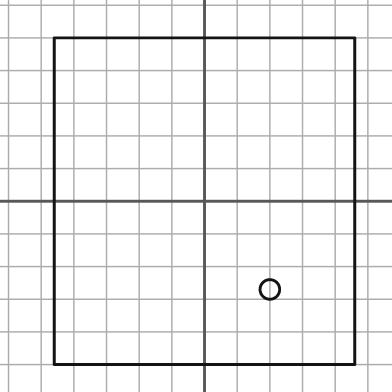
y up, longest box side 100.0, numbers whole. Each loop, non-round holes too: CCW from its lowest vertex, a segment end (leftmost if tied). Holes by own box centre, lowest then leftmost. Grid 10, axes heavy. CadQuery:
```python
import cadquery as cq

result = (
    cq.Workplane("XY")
    .moveTo(-46.0, -50.0)
    .lineTo(46.0, -50.0)
    .lineTo(46.0, 50.0)
    .lineTo(-46.0, 50.0)
    .close()
    .moveTo(20.0, -27.0)
    .circle(3.0)
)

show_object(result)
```